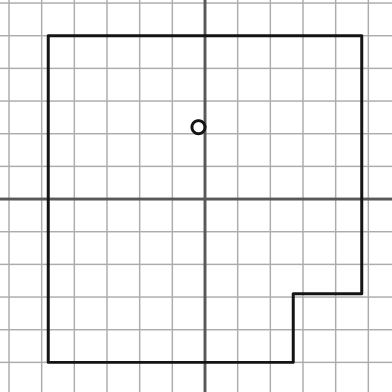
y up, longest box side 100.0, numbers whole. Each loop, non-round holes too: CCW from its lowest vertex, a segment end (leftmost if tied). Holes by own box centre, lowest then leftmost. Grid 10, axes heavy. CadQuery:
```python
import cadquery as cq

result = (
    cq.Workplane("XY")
    .moveTo(-48.0, -50.0)
    .lineTo(27.0, -50.0)
    .lineTo(27.0, -29.0)
    .lineTo(48.0, -29.0)
    .lineTo(48.0, 50.0)
    .lineTo(-48.0, 50.0)
    .close()
    .moveTo(-2.0, 22.0)
    .circle(2.0)
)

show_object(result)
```